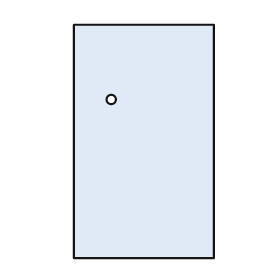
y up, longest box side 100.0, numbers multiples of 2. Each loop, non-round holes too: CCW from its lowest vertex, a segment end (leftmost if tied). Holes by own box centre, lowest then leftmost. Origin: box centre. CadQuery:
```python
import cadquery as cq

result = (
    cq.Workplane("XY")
    .moveTo(-30.0, -50.0)
    .lineTo(30.0, -50.0)
    .lineTo(30.0, 50.0)
    .lineTo(-30.0, 50.0)
    .close()
    .moveTo(-14.0, 18.0)
    .circle(2.0)
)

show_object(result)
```